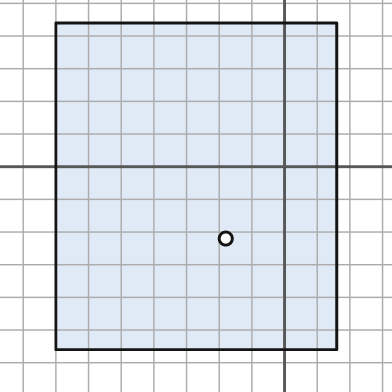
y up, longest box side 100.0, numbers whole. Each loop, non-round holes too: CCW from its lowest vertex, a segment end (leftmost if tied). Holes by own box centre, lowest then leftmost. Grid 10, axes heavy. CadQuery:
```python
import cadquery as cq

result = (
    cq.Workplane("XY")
    .moveTo(-70.0, -56.0)
    .lineTo(16.0, -56.0)
    .lineTo(16.0, 44.0)
    .lineTo(-70.0, 44.0)
    .close()
    .moveTo(-18.0, -22.0)
    .circle(2.0)
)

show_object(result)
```